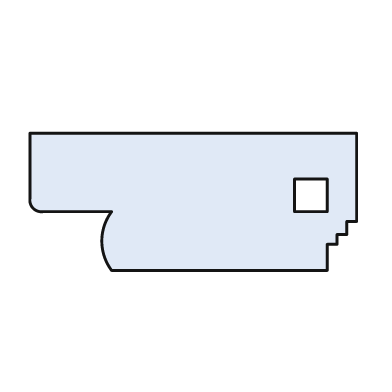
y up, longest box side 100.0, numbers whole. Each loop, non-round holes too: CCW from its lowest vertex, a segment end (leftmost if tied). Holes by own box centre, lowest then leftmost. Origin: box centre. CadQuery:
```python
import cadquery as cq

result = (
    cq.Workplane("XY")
    .moveTo(-25.0, -21.0)
    .lineTo(41.0, -21.0)
    .lineTo(41.0, -13.0)
    .lineTo(44.0, -13.0)
    .lineTo(44.0, -10.0)
    .lineTo(47.0, -10.0)
    .lineTo(47.0, -6.0)
    .lineTo(50.0, -6.0)
    .lineTo(50.0, 21.0)
    .lineTo(-50.0, 21.0)
    .lineTo(-50.0, 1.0)
    .threePointArc((-49.0, -2.0), (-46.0, -3.0))
    .lineTo(-25.0, -3.0)
    .threePointArc((-28.0, -12.0), (-25.0, -21.0))
    .close()
    .moveTo(31.0, -3.0)
    .lineTo(41.0, -3.0)
    .lineTo(41.0, 7.0)
    .lineTo(31.0, 7.0)
    .close()
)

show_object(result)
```